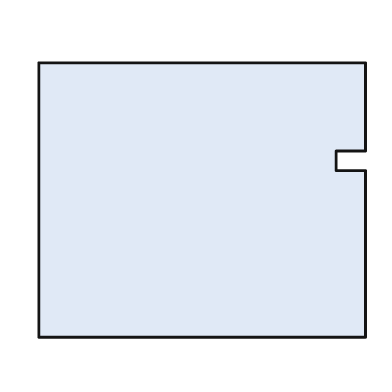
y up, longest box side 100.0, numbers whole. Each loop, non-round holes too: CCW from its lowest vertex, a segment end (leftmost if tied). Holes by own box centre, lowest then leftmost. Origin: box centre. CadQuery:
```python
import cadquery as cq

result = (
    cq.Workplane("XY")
    .moveTo(-50.0, -42.0)
    .lineTo(50.0, -42.0)
    .lineTo(50.0, 9.0)
    .lineTo(41.0, 9.0)
    .lineTo(41.0, 15.0)
    .lineTo(50.0, 15.0)
    .lineTo(50.0, 42.0)
    .lineTo(-50.0, 42.0)
    .close()
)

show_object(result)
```